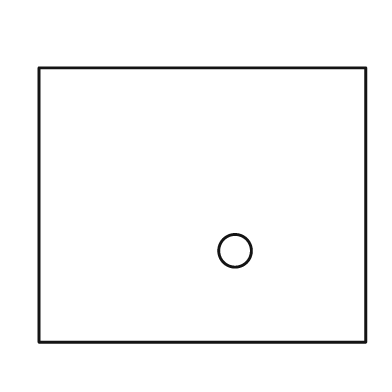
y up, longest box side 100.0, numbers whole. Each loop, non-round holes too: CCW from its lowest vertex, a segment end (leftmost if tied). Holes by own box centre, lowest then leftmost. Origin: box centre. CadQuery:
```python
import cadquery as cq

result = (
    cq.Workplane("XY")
    .moveTo(-50.0, -42.0)
    .lineTo(50.0, -42.0)
    .lineTo(50.0, 42.0)
    .lineTo(-50.0, 42.0)
    .close()
    .moveTo(10.0, -14.0)
    .circle(5.0)
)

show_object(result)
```